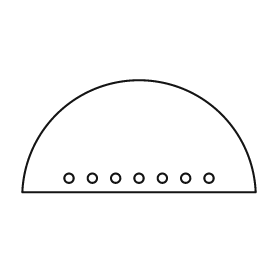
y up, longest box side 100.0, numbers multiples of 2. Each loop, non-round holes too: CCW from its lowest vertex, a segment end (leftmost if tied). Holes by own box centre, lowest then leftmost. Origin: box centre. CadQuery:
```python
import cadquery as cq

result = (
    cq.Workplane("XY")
    .moveTo(-50.0, -24.0)
    .lineTo(50.0, -24.0)
    .threePointArc((0.0, 24.0), (-50.0, -24.0))
    .close()
    .moveTo(-30.0, -18.0)
    .circle(2.0)
    .moveTo(-20.0, -18.0)
    .circle(2.0)
    .moveTo(-10.0, -18.0)
    .circle(2.0)
    .moveTo(0.0, -18.0)
    .circle(2.0)
    .moveTo(10.0, -18.0)
    .circle(2.0)
    .moveTo(20.0, -18.0)
    .circle(2.0)
    .moveTo(30.0, -18.0)
    .circle(2.0)
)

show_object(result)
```